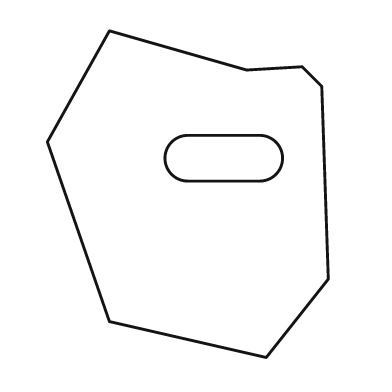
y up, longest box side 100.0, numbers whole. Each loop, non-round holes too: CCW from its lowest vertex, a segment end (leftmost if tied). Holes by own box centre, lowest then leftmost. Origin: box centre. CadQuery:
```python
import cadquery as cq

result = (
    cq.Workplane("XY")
    .moveTo(24.0, -50.0)
    .lineTo(43.0, -26.0)
    .lineTo(41.0, 33.0)
    .lineTo(35.0, 39.0)
    .lineTo(18.0, 38.0)
    .lineTo(-24.0, 50.0)
    .lineTo(-43.0, 16.0)
    .lineTo(-24.0, -39.0)
    .close()
    .moveTo(0.0, 4.0)
    .lineTo(22.0, 4.0)
    .threePointArc((29.0, 11.0), (22.0, 18.0))
    .lineTo(0.0, 18.0)
    .threePointArc((-7.0, 11.0), (0.0, 4.0))
    .close()
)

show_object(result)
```